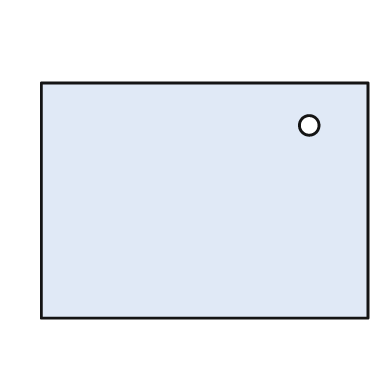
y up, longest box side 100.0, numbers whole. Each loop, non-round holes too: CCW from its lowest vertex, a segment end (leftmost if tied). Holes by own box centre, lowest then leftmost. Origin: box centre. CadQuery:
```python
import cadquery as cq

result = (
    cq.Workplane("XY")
    .moveTo(-50.0, -36.0)
    .lineTo(50.0, -36.0)
    .lineTo(50.0, 36.0)
    .lineTo(-50.0, 36.0)
    .close()
    .moveTo(32.0, 23.0)
    .circle(3.0)
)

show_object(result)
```